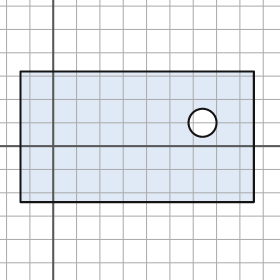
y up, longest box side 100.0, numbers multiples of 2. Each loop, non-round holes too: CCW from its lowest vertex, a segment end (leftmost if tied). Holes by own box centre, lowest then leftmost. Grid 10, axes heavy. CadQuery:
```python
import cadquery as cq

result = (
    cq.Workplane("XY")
    .moveTo(-14.0, -24.0)
    .lineTo(86.0, -24.0)
    .lineTo(86.0, 32.0)
    .lineTo(-14.0, 32.0)
    .close()
    .moveTo(64.0, 10.0)
    .circle(6.0)
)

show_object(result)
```